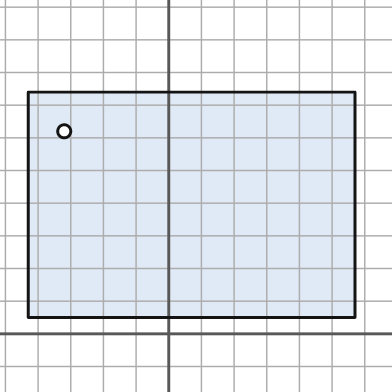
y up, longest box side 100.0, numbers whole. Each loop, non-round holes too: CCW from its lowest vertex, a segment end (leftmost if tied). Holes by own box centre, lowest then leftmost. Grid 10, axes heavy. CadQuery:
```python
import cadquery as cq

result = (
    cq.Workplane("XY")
    .moveTo(-43.0, 5.0)
    .lineTo(57.0, 5.0)
    .lineTo(57.0, 74.0)
    .lineTo(-43.0, 74.0)
    .close()
    .moveTo(-32.0, 62.0)
    .circle(2.0)
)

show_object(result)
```